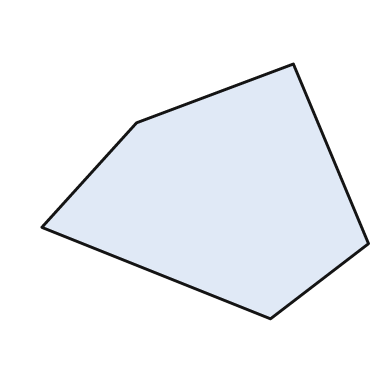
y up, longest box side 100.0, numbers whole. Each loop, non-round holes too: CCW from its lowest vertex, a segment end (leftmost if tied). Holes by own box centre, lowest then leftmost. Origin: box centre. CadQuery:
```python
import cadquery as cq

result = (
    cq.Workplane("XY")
    .moveTo(20.0, -39.0)
    .lineTo(50.0, -16.0)
    .lineTo(27.0, 39.0)
    .lineTo(-21.0, 21.0)
    .lineTo(-50.0, -11.0)
    .close()
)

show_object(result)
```